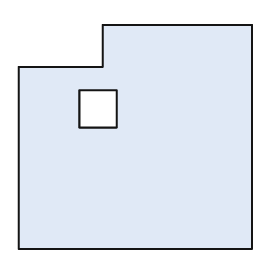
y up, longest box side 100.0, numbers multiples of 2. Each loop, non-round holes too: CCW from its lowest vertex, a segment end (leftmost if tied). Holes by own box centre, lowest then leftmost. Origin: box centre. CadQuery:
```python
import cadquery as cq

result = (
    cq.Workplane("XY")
    .moveTo(-50.0, -48.0)
    .lineTo(50.0, -48.0)
    .lineTo(50.0, 48.0)
    .lineTo(-14.0, 48.0)
    .lineTo(-14.0, 30.0)
    .lineTo(-50.0, 30.0)
    .close()
    .moveTo(-24.0, 4.0)
    .lineTo(-8.0, 4.0)
    .lineTo(-8.0, 20.0)
    .lineTo(-24.0, 20.0)
    .close()
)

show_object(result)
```